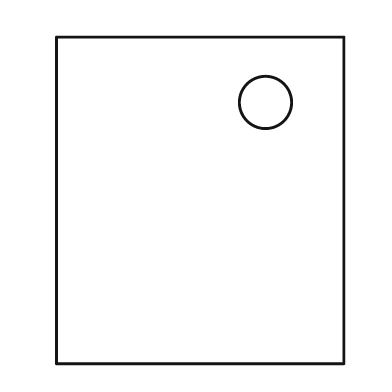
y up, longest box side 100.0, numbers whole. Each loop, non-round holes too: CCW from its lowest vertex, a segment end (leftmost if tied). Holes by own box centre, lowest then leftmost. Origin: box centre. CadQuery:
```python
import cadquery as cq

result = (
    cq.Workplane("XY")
    .moveTo(-44.0, -50.0)
    .lineTo(44.0, -50.0)
    .lineTo(44.0, 50.0)
    .lineTo(-44.0, 50.0)
    .close()
    .moveTo(20.0, 30.0)
    .circle(8.0)
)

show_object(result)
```